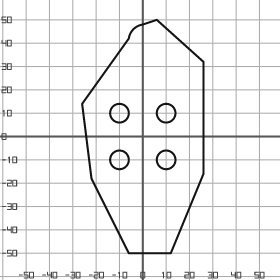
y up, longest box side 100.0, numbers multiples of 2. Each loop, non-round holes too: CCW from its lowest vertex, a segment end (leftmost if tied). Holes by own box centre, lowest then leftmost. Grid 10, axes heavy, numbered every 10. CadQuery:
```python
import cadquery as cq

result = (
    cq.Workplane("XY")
    .moveTo(-6.0, -50.0)
    .lineTo(12.0, -50.0)
    .lineTo(26.0, -16.0)
    .lineTo(26.0, 32.0)
    .lineTo(6.0, 50.0)
    .lineTo(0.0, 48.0)
    .threePointArc((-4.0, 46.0), (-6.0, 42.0))
    .lineTo(-26.0, 14.0)
    .lineTo(-22.0, -18.0)
    .close()
    .moveTo(-10.0, -10.0)
    .circle(4.0)
    .moveTo(10.0, -10.0)
    .circle(4.0)
    .moveTo(-10.0, 10.0)
    .circle(4.0)
    .moveTo(10.0, 10.0)
    .circle(4.0)
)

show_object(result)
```